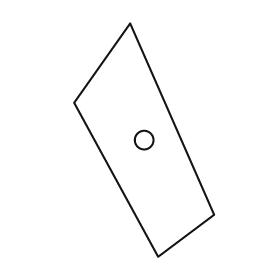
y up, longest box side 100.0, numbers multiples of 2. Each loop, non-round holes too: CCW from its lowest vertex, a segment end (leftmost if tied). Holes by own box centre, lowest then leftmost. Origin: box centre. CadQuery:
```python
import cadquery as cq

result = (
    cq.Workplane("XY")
    .moveTo(6.0, -50.0)
    .lineTo(30.0, -32.0)
    .lineTo(-6.0, 50.0)
    .lineTo(-30.0, 16.0)
    .close()
    .moveTo(0.0, 0.0)
    .circle(4.0)
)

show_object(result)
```